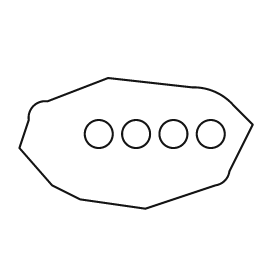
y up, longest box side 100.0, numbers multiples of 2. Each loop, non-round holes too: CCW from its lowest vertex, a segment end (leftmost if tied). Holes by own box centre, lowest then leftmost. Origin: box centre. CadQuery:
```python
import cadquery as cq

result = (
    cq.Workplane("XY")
    .moveTo(4.0, -28.0)
    .lineTo(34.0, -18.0)
    .threePointArc((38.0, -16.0), (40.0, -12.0))
    .lineTo(50.0, 8.0)
    .lineTo(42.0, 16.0)
    .threePointArc((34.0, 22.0), (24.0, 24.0))
    .lineTo(-12.0, 28.0)
    .lineTo(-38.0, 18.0)
    .threePointArc((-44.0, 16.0), (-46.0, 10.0))
    .lineTo(-50.0, -2.0)
    .lineTo(-36.0, -18.0)
    .lineTo(-24.0, -24.0)
    .close()
    .moveTo(-16.0, 4.0)
    .circle(6.0)
    .moveTo(0.0, 4.0)
    .circle(6.0)
    .moveTo(16.0, 4.0)
    .circle(6.0)
    .moveTo(32.0, 4.0)
    .circle(6.0)
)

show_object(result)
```